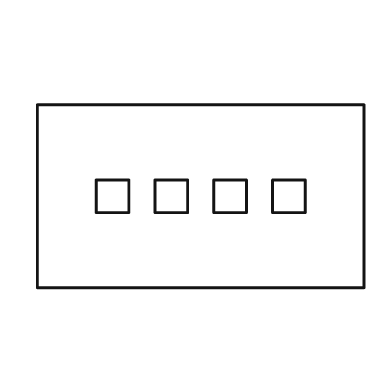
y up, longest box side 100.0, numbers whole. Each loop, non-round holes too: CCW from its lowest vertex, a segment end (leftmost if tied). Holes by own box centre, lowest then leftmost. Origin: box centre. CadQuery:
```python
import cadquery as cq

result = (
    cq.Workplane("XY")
    .moveTo(-50.0, -28.0)
    .lineTo(50.0, -28.0)
    .lineTo(50.0, 28.0)
    .lineTo(-50.0, 28.0)
    .close()
    .moveTo(-32.0, -5.0)
    .lineTo(-22.0, -5.0)
    .lineTo(-22.0, 5.0)
    .lineTo(-32.0, 5.0)
    .close()
    .moveTo(-14.0, -5.0)
    .lineTo(-4.0, -5.0)
    .lineTo(-4.0, 5.0)
    .lineTo(-14.0, 5.0)
    .close()
    .moveTo(4.0, -5.0)
    .lineTo(14.0, -5.0)
    .lineTo(14.0, 5.0)
    .lineTo(4.0, 5.0)
    .close()
    .moveTo(22.0, -5.0)
    .lineTo(32.0, -5.0)
    .lineTo(32.0, 5.0)
    .lineTo(22.0, 5.0)
    .close()
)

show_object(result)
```